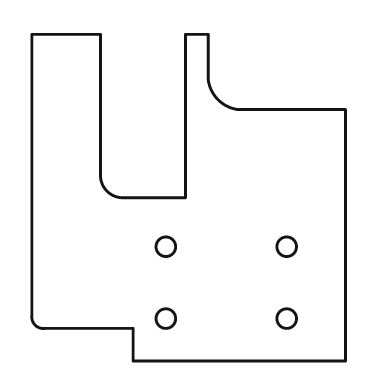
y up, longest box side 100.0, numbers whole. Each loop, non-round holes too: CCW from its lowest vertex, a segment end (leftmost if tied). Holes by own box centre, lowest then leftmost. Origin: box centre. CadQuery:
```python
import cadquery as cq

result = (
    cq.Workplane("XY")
    .moveTo(-17.0, -50.0)
    .lineTo(48.0, -50.0)
    .lineTo(48.0, 27.0)
    .lineTo(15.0, 27.0)
    .threePointArc((9.0, 30.0), (6.0, 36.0))
    .lineTo(6.0, 50.0)
    .lineTo(-1.0, 50.0)
    .lineTo(-1.0, 0.0)
    .lineTo(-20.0, 0.0)
    .threePointArc((-25.0, 2.0), (-27.0, 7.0))
    .lineTo(-27.0, 50.0)
    .lineTo(-48.0, 50.0)
    .lineTo(-48.0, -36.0)
    .threePointArc((-47.0, -39.0), (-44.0, -40.0))
    .lineTo(-17.0, -40.0)
    .close()
    .moveTo(-7.0, -37.0)
    .circle(3.0)
    .moveTo(30.0, -37.0)
    .circle(3.0)
    .moveTo(-7.0, -15.0)
    .circle(3.0)
    .moveTo(30.0, -15.0)
    .circle(3.0)
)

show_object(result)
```